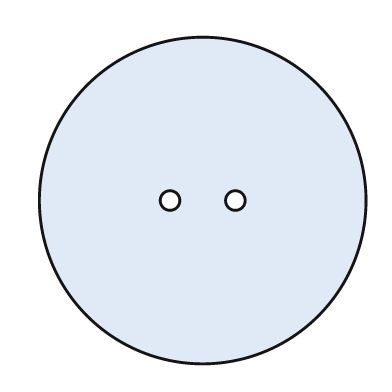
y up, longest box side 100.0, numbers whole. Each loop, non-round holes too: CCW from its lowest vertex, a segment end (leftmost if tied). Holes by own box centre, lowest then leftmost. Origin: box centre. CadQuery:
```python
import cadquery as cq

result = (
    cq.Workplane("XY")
    .moveTo(0.0, 0.0)
    .circle(50.0)
    .moveTo(-10.0, 0.0)
    .circle(3.0)
    .moveTo(10.0, 0.0)
    .circle(3.0)
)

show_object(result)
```